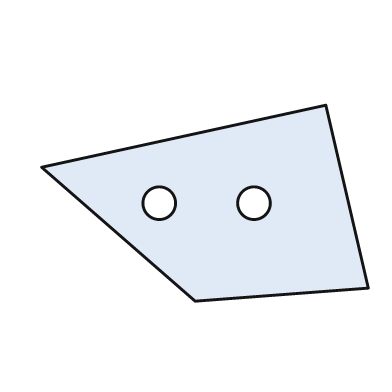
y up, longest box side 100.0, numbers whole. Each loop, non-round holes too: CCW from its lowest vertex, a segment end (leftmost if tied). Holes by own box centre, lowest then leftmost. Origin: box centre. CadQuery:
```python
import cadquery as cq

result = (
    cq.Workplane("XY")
    .moveTo(-3.0, -30.0)
    .lineTo(50.0, -26.0)
    .lineTo(37.0, 30.0)
    .lineTo(-50.0, 11.0)
    .close()
    .moveTo(-14.0, 0.0)
    .circle(5.0)
    .moveTo(15.0, 0.0)
    .circle(5.0)
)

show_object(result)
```